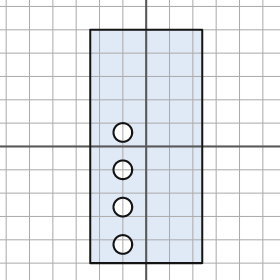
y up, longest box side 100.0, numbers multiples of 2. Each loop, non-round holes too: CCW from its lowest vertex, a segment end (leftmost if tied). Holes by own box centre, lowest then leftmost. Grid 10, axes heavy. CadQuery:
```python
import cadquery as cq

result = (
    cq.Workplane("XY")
    .moveTo(-24.0, -50.0)
    .lineTo(24.0, -50.0)
    .lineTo(24.0, 50.0)
    .lineTo(-24.0, 50.0)
    .close()
    .moveTo(-10.0, -42.0)
    .circle(4.0)
    .moveTo(-10.0, -26.0)
    .circle(4.0)
    .moveTo(-10.0, -10.0)
    .circle(4.0)
    .moveTo(-10.0, 6.0)
    .circle(4.0)
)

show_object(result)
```